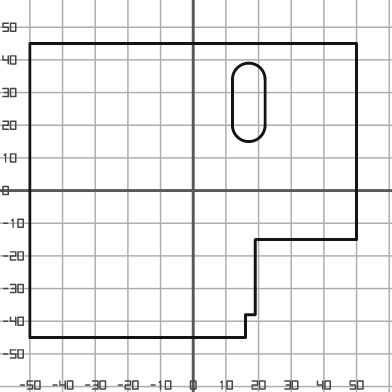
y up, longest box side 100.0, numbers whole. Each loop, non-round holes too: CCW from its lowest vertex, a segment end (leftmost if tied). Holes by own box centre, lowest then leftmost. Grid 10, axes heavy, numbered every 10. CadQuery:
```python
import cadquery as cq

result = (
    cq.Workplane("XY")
    .moveTo(-50.0, -45.0)
    .lineTo(16.0, -45.0)
    .lineTo(16.0, -38.0)
    .lineTo(19.0, -38.0)
    .lineTo(19.0, -15.0)
    .lineTo(50.0, -15.0)
    .lineTo(50.0, 45.0)
    .lineTo(-50.0, 45.0)
    .close()
    .moveTo(12.0, 20.0)
    .threePointArc((17.0, 15.0), (22.0, 20.0))
    .lineTo(22.0, 34.0)
    .threePointArc((17.0, 39.0), (12.0, 34.0))
    .close()
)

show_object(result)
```